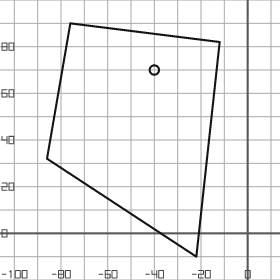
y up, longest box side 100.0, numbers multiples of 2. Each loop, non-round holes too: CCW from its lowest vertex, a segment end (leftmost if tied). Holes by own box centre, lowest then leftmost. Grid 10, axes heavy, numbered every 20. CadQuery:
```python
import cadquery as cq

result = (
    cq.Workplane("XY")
    .moveTo(-22.0, -10.0)
    .lineTo(-12.0, 82.0)
    .lineTo(-76.0, 90.0)
    .lineTo(-86.0, 32.0)
    .close()
    .moveTo(-40.0, 70.0)
    .circle(2.0)
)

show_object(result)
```